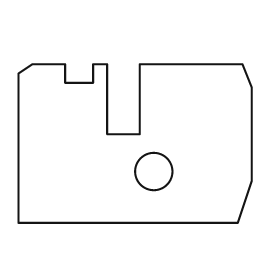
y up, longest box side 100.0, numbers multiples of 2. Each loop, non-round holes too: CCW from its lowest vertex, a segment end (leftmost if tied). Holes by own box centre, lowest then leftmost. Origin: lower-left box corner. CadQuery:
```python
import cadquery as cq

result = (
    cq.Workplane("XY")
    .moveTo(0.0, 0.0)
    .lineTo(94.0, 0.0)
    .lineTo(100.0, 18.0)
    .lineTo(100.0, 58.0)
    .lineTo(96.0, 68.0)
    .lineTo(52.0, 68.0)
    .lineTo(52.0, 38.0)
    .lineTo(38.0, 38.0)
    .lineTo(38.0, 68.0)
    .lineTo(32.0, 68.0)
    .lineTo(32.0, 60.0)
    .lineTo(20.0, 60.0)
    .lineTo(20.0, 68.0)
    .lineTo(6.0, 68.0)
    .lineTo(0.0, 64.0)
    .close()
    .moveTo(58.0, 22.0)
    .circle(8.0)
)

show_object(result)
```